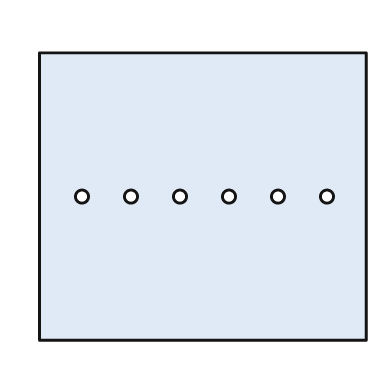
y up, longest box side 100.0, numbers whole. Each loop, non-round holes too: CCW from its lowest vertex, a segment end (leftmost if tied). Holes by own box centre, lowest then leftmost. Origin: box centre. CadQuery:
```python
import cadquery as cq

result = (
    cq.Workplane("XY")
    .moveTo(-50.0, -44.0)
    .lineTo(50.0, -44.0)
    .lineTo(50.0, 44.0)
    .lineTo(-50.0, 44.0)
    .close()
    .moveTo(-37.0, 0.0)
    .circle(2.0)
    .moveTo(-22.0, 0.0)
    .circle(2.0)
    .moveTo(-7.0, 0.0)
    .circle(2.0)
    .moveTo(8.0, 0.0)
    .circle(2.0)
    .moveTo(23.0, 0.0)
    .circle(2.0)
    .moveTo(38.0, 0.0)
    .circle(2.0)
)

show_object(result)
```